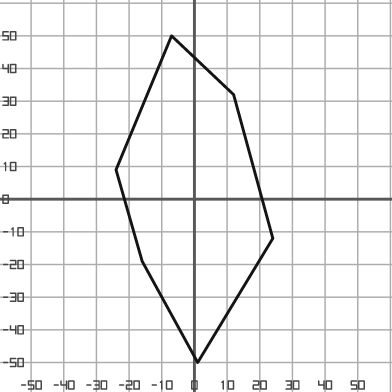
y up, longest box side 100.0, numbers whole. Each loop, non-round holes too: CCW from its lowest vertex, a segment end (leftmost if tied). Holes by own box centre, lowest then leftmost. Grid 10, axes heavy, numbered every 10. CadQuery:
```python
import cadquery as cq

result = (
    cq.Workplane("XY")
    .moveTo(1.0, -50.0)
    .lineTo(24.0, -12.0)
    .lineTo(12.0, 32.0)
    .lineTo(-7.0, 50.0)
    .lineTo(-24.0, 9.0)
    .lineTo(-16.0, -19.0)
    .close()
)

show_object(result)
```